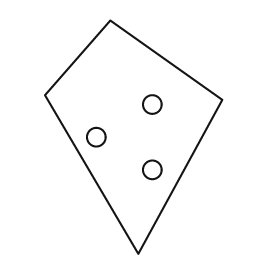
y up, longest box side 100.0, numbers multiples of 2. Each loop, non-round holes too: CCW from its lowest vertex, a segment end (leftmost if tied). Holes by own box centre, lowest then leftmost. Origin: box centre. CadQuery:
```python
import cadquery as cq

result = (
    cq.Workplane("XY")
    .moveTo(2.0, -50.0)
    .lineTo(38.0, 16.0)
    .lineTo(-10.0, 50.0)
    .lineTo(-38.0, 18.0)
    .close()
    .moveTo(8.0, -14.0)
    .circle(4.0)
    .moveTo(-16.0, 0.0)
    .circle(4.0)
    .moveTo(8.0, 14.0)
    .circle(4.0)
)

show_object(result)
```